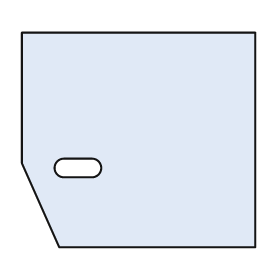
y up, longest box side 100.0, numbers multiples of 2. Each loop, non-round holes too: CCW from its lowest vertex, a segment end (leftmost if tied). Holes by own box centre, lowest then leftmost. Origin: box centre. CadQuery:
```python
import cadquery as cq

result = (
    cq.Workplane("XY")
    .moveTo(-34.0, -46.0)
    .lineTo(50.0, -46.0)
    .lineTo(50.0, 46.0)
    .lineTo(-50.0, 46.0)
    .lineTo(-50.0, -10.0)
    .close()
    .moveTo(-32.0, -16.0)
    .lineTo(-20.0, -16.0)
    .threePointArc((-16.0, -12.0), (-20.0, -8.0))
    .lineTo(-32.0, -8.0)
    .threePointArc((-36.0, -12.0), (-32.0, -16.0))
    .close()
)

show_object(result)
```